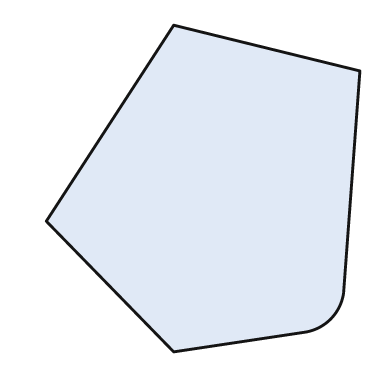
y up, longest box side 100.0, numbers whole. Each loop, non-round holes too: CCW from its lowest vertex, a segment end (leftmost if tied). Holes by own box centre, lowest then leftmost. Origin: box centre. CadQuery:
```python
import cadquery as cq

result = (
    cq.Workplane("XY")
    .moveTo(-9.0, -50.0)
    .lineTo(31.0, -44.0)
    .threePointArc((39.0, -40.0), (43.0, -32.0))
    .lineTo(48.0, 36.0)
    .lineTo(-9.0, 50.0)
    .lineTo(-48.0, -10.0)
    .close()
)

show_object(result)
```